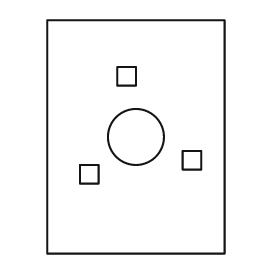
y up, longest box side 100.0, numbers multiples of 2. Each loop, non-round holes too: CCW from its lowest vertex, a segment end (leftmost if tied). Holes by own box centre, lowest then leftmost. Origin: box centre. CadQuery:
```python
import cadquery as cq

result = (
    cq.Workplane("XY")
    .moveTo(-38.0, -50.0)
    .lineTo(38.0, -50.0)
    .lineTo(38.0, 50.0)
    .lineTo(-38.0, 50.0)
    .close()
    .moveTo(-24.0, -20.0)
    .lineTo(-16.0, -20.0)
    .lineTo(-16.0, -12.0)
    .lineTo(-24.0, -12.0)
    .close()
    .moveTo(20.0, -14.0)
    .lineTo(28.0, -14.0)
    .lineTo(28.0, -6.0)
    .lineTo(20.0, -6.0)
    .close()
    .moveTo(0.0, 0.0)
    .circle(12.0)
    .moveTo(-8.0, 22.0)
    .lineTo(0.0, 22.0)
    .lineTo(0.0, 30.0)
    .lineTo(-8.0, 30.0)
    .close()
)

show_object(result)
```